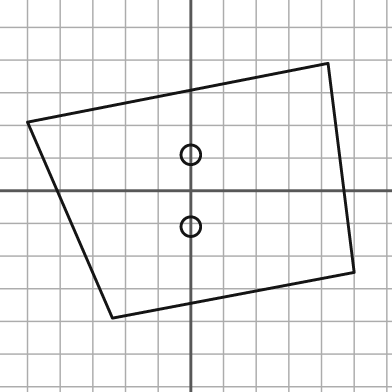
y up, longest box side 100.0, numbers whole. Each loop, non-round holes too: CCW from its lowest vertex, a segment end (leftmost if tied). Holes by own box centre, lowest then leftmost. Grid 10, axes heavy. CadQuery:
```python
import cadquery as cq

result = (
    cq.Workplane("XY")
    .moveTo(-24.0, -39.0)
    .lineTo(50.0, -25.0)
    .lineTo(42.0, 39.0)
    .lineTo(-50.0, 21.0)
    .close()
    .moveTo(0.0, -11.0)
    .circle(3.0)
    .moveTo(0.0, 11.0)
    .circle(3.0)
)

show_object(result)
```